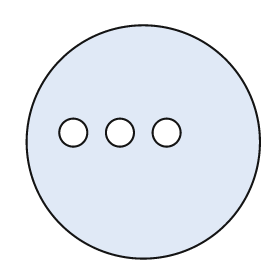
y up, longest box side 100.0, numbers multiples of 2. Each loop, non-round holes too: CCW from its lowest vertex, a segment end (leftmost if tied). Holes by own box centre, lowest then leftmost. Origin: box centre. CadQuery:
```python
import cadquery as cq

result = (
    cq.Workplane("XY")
    .moveTo(0.0, 0.0)
    .circle(50.0)
    .moveTo(-30.0, 4.0)
    .circle(6.0)
    .moveTo(-10.0, 4.0)
    .circle(6.0)
    .moveTo(10.0, 4.0)
    .circle(6.0)
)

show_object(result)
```